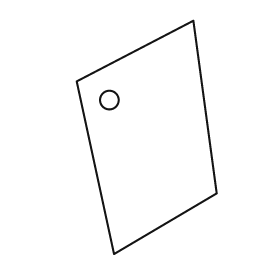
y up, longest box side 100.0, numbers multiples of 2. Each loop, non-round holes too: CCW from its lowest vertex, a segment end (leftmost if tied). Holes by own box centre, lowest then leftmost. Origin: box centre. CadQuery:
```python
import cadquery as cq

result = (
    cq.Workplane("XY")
    .moveTo(-14.0, -50.0)
    .lineTo(30.0, -24.0)
    .lineTo(20.0, 50.0)
    .lineTo(-30.0, 24.0)
    .close()
    .moveTo(-16.0, 16.0)
    .circle(4.0)
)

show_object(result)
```